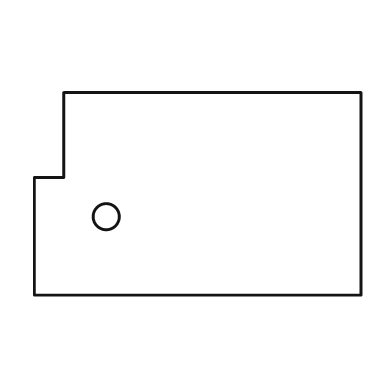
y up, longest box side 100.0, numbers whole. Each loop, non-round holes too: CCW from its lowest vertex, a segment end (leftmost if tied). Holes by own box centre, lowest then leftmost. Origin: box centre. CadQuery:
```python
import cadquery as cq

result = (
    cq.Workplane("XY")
    .moveTo(-50.0, -31.0)
    .lineTo(50.0, -31.0)
    .lineTo(50.0, 31.0)
    .lineTo(-41.0, 31.0)
    .lineTo(-41.0, 5.0)
    .lineTo(-50.0, 5.0)
    .close()
    .moveTo(-28.0, -7.0)
    .circle(4.0)
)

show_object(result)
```